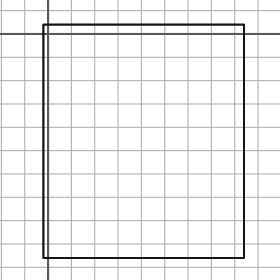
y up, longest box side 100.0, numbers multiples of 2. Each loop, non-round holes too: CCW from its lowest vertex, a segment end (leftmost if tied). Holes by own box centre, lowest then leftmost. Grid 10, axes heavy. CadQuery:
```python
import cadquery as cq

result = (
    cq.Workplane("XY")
    .moveTo(-2.0, -96.0)
    .lineTo(84.0, -96.0)
    .lineTo(84.0, 4.0)
    .lineTo(-2.0, 4.0)
    .close()
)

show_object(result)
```